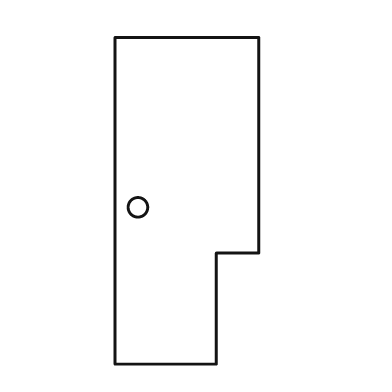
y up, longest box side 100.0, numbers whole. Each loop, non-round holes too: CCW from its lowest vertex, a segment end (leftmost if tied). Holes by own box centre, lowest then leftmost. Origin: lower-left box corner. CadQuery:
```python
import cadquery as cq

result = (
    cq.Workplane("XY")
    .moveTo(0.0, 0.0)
    .lineTo(31.0, 0.0)
    .lineTo(31.0, 34.0)
    .lineTo(44.0, 34.0)
    .lineTo(44.0, 100.0)
    .lineTo(0.0, 100.0)
    .close()
    .moveTo(7.0, 48.0)
    .circle(3.0)
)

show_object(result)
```